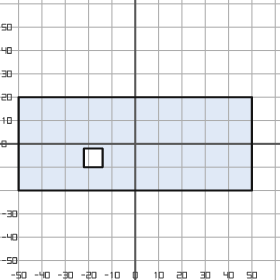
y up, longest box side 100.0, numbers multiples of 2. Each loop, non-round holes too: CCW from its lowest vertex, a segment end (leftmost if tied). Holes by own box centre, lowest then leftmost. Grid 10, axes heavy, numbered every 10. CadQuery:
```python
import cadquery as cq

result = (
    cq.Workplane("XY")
    .moveTo(-50.0, -20.0)
    .lineTo(50.0, -20.0)
    .lineTo(50.0, 20.0)
    .lineTo(-50.0, 20.0)
    .close()
    .moveTo(-22.0, -10.0)
    .lineTo(-14.0, -10.0)
    .lineTo(-14.0, -2.0)
    .lineTo(-22.0, -2.0)
    .close()
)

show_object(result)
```